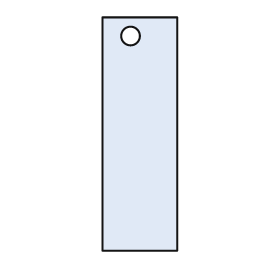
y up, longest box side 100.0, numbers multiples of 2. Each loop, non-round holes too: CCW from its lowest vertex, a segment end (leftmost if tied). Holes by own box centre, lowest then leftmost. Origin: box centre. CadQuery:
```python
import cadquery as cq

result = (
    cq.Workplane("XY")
    .moveTo(-16.0, -50.0)
    .lineTo(16.0, -50.0)
    .lineTo(16.0, 50.0)
    .lineTo(-16.0, 50.0)
    .close()
    .moveTo(-4.0, 42.0)
    .circle(4.0)
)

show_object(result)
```